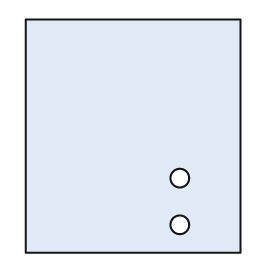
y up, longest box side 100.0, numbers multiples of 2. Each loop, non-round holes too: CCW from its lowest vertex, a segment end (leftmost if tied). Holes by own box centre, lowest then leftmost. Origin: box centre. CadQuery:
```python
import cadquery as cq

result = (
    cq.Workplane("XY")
    .moveTo(-46.0, -50.0)
    .lineTo(46.0, -50.0)
    .lineTo(46.0, 50.0)
    .lineTo(-46.0, 50.0)
    .close()
    .moveTo(20.0, -38.0)
    .circle(4.0)
    .moveTo(20.0, -18.0)
    .circle(4.0)
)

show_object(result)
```